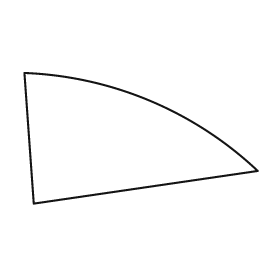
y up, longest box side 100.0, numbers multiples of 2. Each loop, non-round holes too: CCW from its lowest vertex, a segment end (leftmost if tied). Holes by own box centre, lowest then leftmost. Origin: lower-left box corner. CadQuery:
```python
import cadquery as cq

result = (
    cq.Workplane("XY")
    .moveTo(4.0, 0.0)
    .lineTo(100.0, 14.0)
    .threePointArc((54.0, 44.0), (0.0, 56.0))
    .close()
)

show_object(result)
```